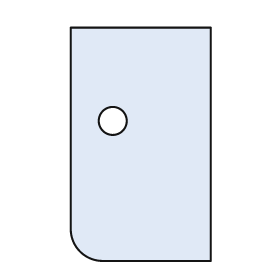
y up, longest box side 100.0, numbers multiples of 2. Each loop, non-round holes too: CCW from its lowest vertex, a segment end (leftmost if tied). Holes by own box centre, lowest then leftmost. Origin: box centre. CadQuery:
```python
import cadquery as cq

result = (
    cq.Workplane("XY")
    .moveTo(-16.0, -50.0)
    .lineTo(30.0, -50.0)
    .lineTo(30.0, 50.0)
    .lineTo(-30.0, 50.0)
    .lineTo(-30.0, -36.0)
    .threePointArc((-26.0, -46.0), (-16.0, -50.0))
    .close()
    .moveTo(-12.0, 10.0)
    .circle(6.0)
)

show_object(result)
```